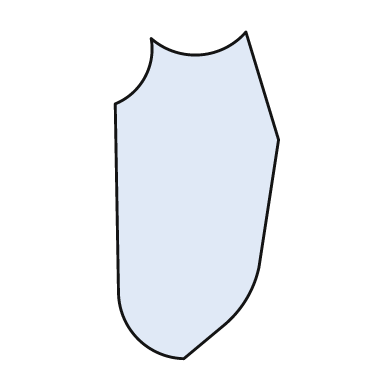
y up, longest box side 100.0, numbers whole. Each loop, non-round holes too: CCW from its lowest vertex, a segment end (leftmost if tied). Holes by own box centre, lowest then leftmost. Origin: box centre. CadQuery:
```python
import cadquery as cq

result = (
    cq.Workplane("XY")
    .moveTo(-4.0, -50.0)
    .lineTo(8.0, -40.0)
    .threePointArc((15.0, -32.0), (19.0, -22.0))
    .lineTo(25.0, 17.0)
    .lineTo(15.0, 50.0)
    .threePointArc((1.0, 43.0), (-14.0, 48.0))
    .threePointArc((-16.0, 36.0), (-25.0, 28.0))
    .lineTo(-24.0, -30.0)
    .threePointArc((-18.0, -44.0), (-4.0, -50.0))
    .close()
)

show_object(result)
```